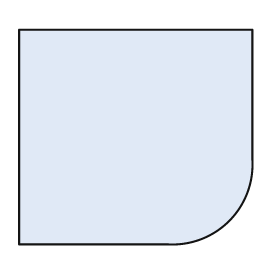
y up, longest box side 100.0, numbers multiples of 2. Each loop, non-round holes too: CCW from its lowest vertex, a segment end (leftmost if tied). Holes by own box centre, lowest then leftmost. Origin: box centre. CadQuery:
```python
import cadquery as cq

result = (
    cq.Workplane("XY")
    .moveTo(-50.0, -46.0)
    .lineTo(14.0, -46.0)
    .threePointArc((40.0, -36.0), (50.0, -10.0))
    .lineTo(50.0, 46.0)
    .lineTo(-50.0, 46.0)
    .close()
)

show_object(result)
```